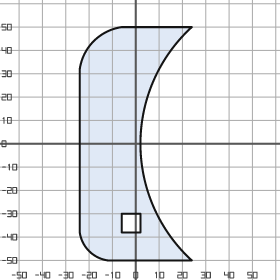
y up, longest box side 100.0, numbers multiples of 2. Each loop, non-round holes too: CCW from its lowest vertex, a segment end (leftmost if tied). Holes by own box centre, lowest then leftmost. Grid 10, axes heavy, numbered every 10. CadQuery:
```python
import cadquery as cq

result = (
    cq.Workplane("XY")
    .moveTo(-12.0, -50.0)
    .lineTo(24.0, -50.0)
    .threePointArc((2.0, 0.0), (24.0, 50.0))
    .lineTo(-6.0, 50.0)
    .threePointArc((-18.0, 44.0), (-24.0, 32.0))
    .lineTo(-24.0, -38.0)
    .threePointArc((-20.0, -46.0), (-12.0, -50.0))
    .close()
    .moveTo(-6.0, -38.0)
    .lineTo(2.0, -38.0)
    .lineTo(2.0, -30.0)
    .lineTo(-6.0, -30.0)
    .close()
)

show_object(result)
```